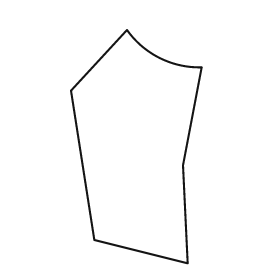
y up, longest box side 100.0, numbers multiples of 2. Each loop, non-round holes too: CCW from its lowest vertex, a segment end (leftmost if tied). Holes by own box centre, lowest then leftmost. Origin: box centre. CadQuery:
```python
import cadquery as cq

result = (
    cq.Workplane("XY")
    .moveTo(22.0, -50.0)
    .lineTo(20.0, -8.0)
    .lineTo(28.0, 34.0)
    .threePointArc((10.0, 38.0), (-4.0, 50.0))
    .lineTo(-28.0, 24.0)
    .lineTo(-18.0, -40.0)
    .close()
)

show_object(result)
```